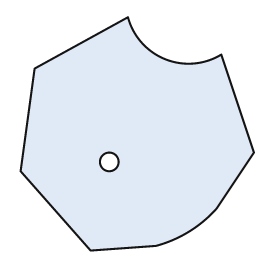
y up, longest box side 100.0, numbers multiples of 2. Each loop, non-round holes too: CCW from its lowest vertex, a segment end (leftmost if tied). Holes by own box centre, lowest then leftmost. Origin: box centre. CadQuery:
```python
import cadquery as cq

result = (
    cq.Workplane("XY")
    .moveTo(-20.0, -50.0)
    .lineTo(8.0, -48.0)
    .threePointArc((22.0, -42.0), (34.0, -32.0))
    .lineTo(50.0, -8.0)
    .lineTo(36.0, 34.0)
    .threePointArc((12.0, 32.0), (-4.0, 50.0))
    .lineTo(-44.0, 28.0)
    .lineTo(-50.0, -16.0)
    .close()
    .moveTo(-12.0, -12.0)
    .circle(4.0)
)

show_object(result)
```